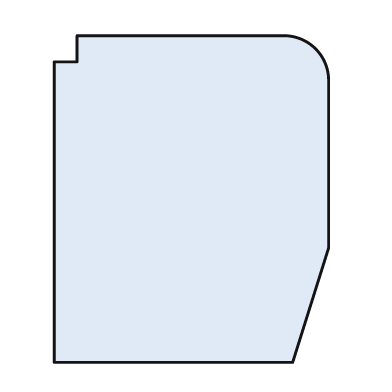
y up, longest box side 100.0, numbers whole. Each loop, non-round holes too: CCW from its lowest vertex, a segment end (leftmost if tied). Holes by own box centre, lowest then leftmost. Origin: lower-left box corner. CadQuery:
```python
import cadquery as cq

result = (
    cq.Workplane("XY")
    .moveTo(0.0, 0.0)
    .lineTo(73.0, 0.0)
    .lineTo(84.0, 35.0)
    .lineTo(84.0, 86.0)
    .threePointArc((80.0, 96.0), (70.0, 100.0))
    .lineTo(7.0, 100.0)
    .lineTo(7.0, 92.0)
    .lineTo(0.0, 92.0)
    .close()
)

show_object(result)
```